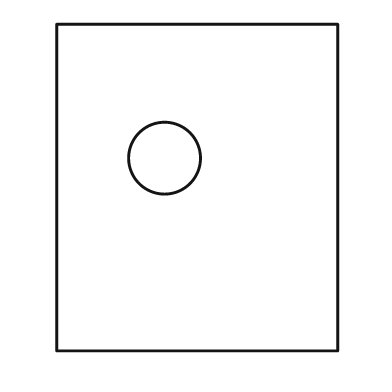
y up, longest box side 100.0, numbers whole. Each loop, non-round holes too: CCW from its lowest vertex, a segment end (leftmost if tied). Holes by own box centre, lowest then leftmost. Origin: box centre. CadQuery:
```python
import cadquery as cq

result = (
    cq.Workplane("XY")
    .moveTo(-43.0, -50.0)
    .lineTo(43.0, -50.0)
    .lineTo(43.0, 50.0)
    .lineTo(-43.0, 50.0)
    .close()
    .moveTo(-10.0, 9.0)
    .circle(11.0)
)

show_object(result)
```